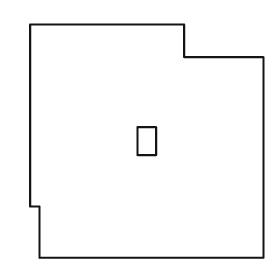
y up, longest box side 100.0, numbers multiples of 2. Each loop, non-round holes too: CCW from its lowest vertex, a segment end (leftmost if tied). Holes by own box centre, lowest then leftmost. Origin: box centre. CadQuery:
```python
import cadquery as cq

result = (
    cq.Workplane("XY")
    .moveTo(-46.0, -50.0)
    .lineTo(50.0, -50.0)
    .lineTo(50.0, 36.0)
    .lineTo(16.0, 36.0)
    .lineTo(16.0, 50.0)
    .lineTo(-50.0, 50.0)
    .lineTo(-50.0, -28.0)
    .lineTo(-46.0, -28.0)
    .close()
    .moveTo(-4.0, -6.0)
    .lineTo(4.0, -6.0)
    .lineTo(4.0, 6.0)
    .lineTo(-4.0, 6.0)
    .close()
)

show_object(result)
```